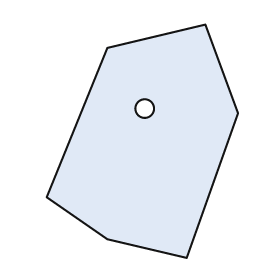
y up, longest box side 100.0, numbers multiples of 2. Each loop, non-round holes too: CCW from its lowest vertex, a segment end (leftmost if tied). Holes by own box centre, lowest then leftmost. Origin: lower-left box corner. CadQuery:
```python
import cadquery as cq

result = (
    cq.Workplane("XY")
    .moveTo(60.0, 0.0)
    .lineTo(82.0, 62.0)
    .lineTo(68.0, 100.0)
    .lineTo(26.0, 90.0)
    .lineTo(0.0, 26.0)
    .lineTo(26.0, 8.0)
    .close()
    .moveTo(42.0, 64.0)
    .circle(4.0)
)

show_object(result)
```